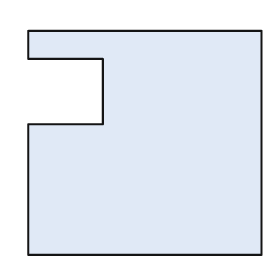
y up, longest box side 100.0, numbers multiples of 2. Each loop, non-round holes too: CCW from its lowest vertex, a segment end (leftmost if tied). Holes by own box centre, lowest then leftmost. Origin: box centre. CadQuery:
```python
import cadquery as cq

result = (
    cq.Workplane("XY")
    .moveTo(-50.0, -48.0)
    .lineTo(50.0, -48.0)
    .lineTo(50.0, 48.0)
    .lineTo(-50.0, 48.0)
    .lineTo(-50.0, 36.0)
    .lineTo(-18.0, 36.0)
    .lineTo(-18.0, 8.0)
    .lineTo(-50.0, 8.0)
    .close()
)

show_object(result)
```